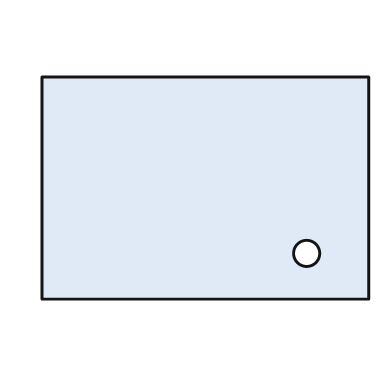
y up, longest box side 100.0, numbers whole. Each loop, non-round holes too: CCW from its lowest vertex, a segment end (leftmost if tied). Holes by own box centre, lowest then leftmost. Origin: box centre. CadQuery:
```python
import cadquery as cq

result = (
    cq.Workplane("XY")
    .moveTo(-50.0, -34.0)
    .lineTo(50.0, -34.0)
    .lineTo(50.0, 34.0)
    .lineTo(-50.0, 34.0)
    .close()
    .moveTo(31.0, -20.0)
    .circle(4.0)
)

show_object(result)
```